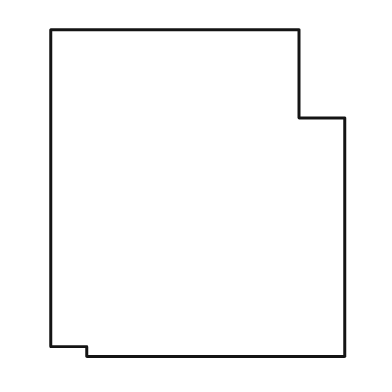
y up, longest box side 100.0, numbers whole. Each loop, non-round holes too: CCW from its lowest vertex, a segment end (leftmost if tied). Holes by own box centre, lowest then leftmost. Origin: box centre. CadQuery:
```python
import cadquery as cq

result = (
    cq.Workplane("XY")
    .moveTo(-34.0, -50.0)
    .lineTo(45.0, -50.0)
    .lineTo(45.0, 23.0)
    .lineTo(31.0, 23.0)
    .lineTo(31.0, 50.0)
    .lineTo(-45.0, 50.0)
    .lineTo(-45.0, -47.0)
    .lineTo(-34.0, -47.0)
    .close()
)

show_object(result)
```